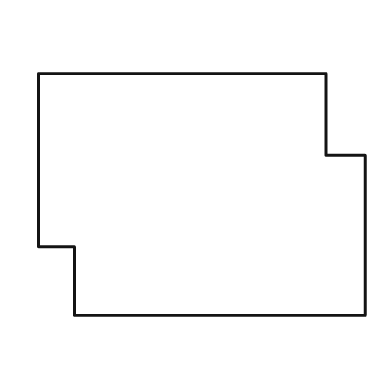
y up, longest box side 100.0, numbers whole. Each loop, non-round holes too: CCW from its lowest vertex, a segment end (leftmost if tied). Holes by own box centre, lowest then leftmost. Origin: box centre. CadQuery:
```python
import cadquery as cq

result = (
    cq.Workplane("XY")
    .moveTo(-39.0, -37.0)
    .lineTo(50.0, -37.0)
    .lineTo(50.0, 12.0)
    .lineTo(38.0, 12.0)
    .lineTo(38.0, 37.0)
    .lineTo(-50.0, 37.0)
    .lineTo(-50.0, -16.0)
    .lineTo(-39.0, -16.0)
    .close()
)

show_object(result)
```